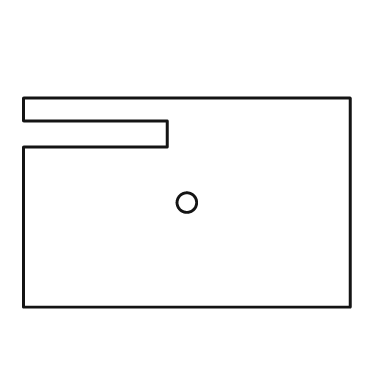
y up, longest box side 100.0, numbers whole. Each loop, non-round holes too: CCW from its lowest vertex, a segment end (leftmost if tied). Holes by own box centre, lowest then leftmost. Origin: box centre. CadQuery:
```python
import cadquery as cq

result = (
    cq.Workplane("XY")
    .moveTo(-50.0, -32.0)
    .lineTo(50.0, -32.0)
    .lineTo(50.0, 32.0)
    .lineTo(-50.0, 32.0)
    .lineTo(-50.0, 25.0)
    .lineTo(-6.0, 25.0)
    .lineTo(-6.0, 17.0)
    .lineTo(-50.0, 17.0)
    .close()
    .moveTo(0.0, 0.0)
    .circle(3.0)
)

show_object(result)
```